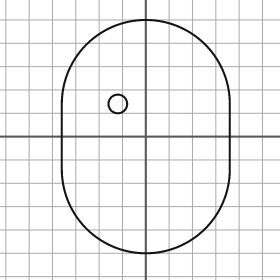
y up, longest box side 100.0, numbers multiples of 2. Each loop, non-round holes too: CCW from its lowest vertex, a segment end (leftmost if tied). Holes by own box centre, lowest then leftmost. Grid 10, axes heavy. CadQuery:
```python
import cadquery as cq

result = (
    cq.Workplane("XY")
    .moveTo(-36.0, -14.0)
    .threePointArc((0.0, -50.0), (36.0, -14.0))
    .lineTo(36.0, 14.0)
    .threePointArc((0.0, 50.0), (-36.0, 14.0))
    .close()
    .moveTo(-12.0, 14.0)
    .circle(4.0)
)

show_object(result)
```